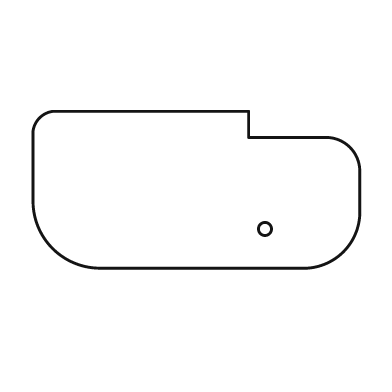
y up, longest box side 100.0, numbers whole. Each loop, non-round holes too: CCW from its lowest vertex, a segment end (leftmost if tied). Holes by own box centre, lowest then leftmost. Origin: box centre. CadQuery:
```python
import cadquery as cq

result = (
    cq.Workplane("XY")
    .moveTo(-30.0, -24.0)
    .lineTo(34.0, -24.0)
    .threePointArc((45.0, -19.0), (50.0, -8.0))
    .lineTo(50.0, 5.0)
    .threePointArc((47.0, 13.0), (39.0, 16.0))
    .lineTo(16.0, 16.0)
    .lineTo(16.0, 24.0)
    .lineTo(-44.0, 24.0)
    .threePointArc((-48.0, 22.0), (-50.0, 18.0))
    .lineTo(-50.0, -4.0)
    .threePointArc((-44.0, -18.0), (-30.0, -24.0))
    .close()
    .moveTo(21.0, -12.0)
    .circle(2.0)
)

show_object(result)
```